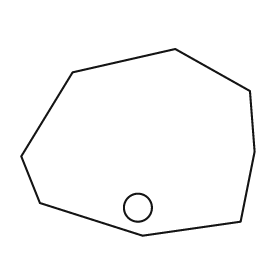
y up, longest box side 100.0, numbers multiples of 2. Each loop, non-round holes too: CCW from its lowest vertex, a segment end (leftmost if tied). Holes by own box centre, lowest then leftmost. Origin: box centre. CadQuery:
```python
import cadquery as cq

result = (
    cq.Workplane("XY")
    .moveTo(2.0, -40.0)
    .lineTo(44.0, -34.0)
    .lineTo(50.0, -4.0)
    .lineTo(48.0, 22.0)
    .lineTo(16.0, 40.0)
    .lineTo(-28.0, 30.0)
    .lineTo(-50.0, -6.0)
    .lineTo(-42.0, -26.0)
    .close()
    .moveTo(0.0, -28.0)
    .circle(6.0)
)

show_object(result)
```